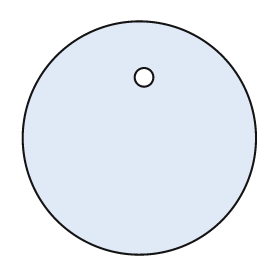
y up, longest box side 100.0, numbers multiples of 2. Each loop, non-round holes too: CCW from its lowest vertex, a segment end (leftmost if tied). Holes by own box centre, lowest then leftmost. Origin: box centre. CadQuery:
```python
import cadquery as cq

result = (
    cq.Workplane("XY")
    .moveTo(0.0, 0.0)
    .circle(50.0)
    .moveTo(2.0, 26.0)
    .circle(4.0)
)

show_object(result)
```